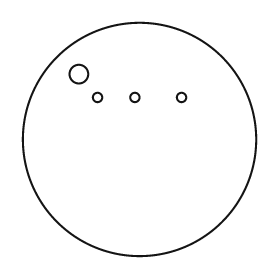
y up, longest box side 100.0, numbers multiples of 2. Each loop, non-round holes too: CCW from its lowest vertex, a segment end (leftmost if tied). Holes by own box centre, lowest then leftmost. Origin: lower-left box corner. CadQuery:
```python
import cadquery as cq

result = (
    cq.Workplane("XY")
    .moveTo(50.0, 50.0)
    .circle(50.0)
    .moveTo(32.0, 68.0)
    .circle(2.0)
    .moveTo(48.0, 68.0)
    .circle(2.0)
    .moveTo(68.0, 68.0)
    .circle(2.0)
    .moveTo(24.0, 78.0)
    .circle(4.0)
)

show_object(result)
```